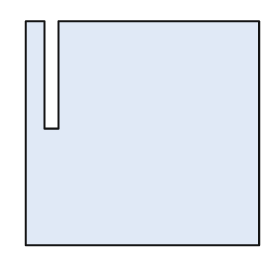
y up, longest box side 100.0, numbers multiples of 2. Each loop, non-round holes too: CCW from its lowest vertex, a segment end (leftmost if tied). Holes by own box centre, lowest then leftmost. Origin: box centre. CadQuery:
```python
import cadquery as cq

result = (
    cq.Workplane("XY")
    .moveTo(-50.0, -48.0)
    .lineTo(50.0, -48.0)
    .lineTo(50.0, 48.0)
    .lineTo(-36.0, 48.0)
    .lineTo(-36.0, 2.0)
    .lineTo(-42.0, 2.0)
    .lineTo(-42.0, 48.0)
    .lineTo(-50.0, 48.0)
    .close()
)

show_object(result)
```